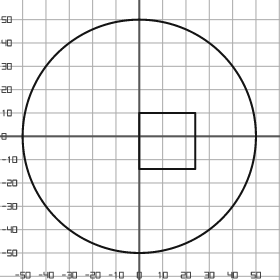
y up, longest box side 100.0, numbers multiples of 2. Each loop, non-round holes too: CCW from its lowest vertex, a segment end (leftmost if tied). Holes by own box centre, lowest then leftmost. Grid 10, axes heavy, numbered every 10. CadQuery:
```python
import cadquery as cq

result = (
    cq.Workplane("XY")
    .moveTo(0.0, 0.0)
    .circle(50.0)
    .moveTo(0.0, -14.0)
    .lineTo(24.0, -14.0)
    .lineTo(24.0, 10.0)
    .lineTo(0.0, 10.0)
    .close()
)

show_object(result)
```